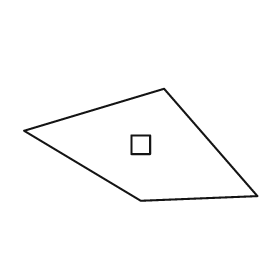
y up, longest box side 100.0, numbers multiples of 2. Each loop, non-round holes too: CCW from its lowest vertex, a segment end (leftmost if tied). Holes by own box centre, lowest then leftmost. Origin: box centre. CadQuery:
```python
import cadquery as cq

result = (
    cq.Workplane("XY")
    .moveTo(0.0, -24.0)
    .lineTo(50.0, -22.0)
    .lineTo(10.0, 24.0)
    .lineTo(-50.0, 6.0)
    .close()
    .moveTo(-4.0, -4.0)
    .lineTo(4.0, -4.0)
    .lineTo(4.0, 4.0)
    .lineTo(-4.0, 4.0)
    .close()
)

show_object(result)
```